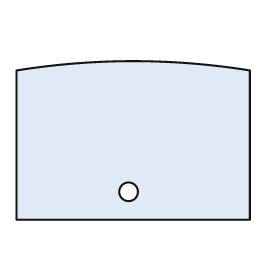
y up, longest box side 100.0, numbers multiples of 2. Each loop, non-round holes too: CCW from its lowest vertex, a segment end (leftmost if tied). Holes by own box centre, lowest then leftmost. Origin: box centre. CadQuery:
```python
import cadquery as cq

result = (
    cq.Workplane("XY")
    .moveTo(-50.0, -34.0)
    .lineTo(50.0, -34.0)
    .lineTo(50.0, 30.0)
    .threePointArc((0.0, 34.0), (-50.0, 30.0))
    .close()
    .moveTo(-2.0, -22.0)
    .circle(4.0)
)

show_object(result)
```